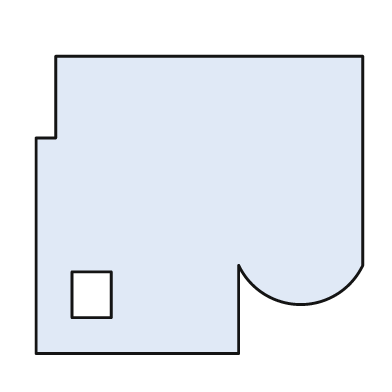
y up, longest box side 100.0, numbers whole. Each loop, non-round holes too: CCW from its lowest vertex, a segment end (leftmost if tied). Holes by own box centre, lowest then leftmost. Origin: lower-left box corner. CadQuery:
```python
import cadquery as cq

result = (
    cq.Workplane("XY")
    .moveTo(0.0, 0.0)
    .lineTo(62.0, 0.0)
    .lineTo(62.0, 27.0)
    .threePointArc((81.0, 15.0), (100.0, 27.0))
    .lineTo(100.0, 91.0)
    .lineTo(6.0, 91.0)
    .lineTo(6.0, 66.0)
    .lineTo(0.0, 66.0)
    .close()
    .moveTo(11.0, 11.0)
    .lineTo(23.0, 11.0)
    .lineTo(23.0, 25.0)
    .lineTo(11.0, 25.0)
    .close()
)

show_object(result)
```